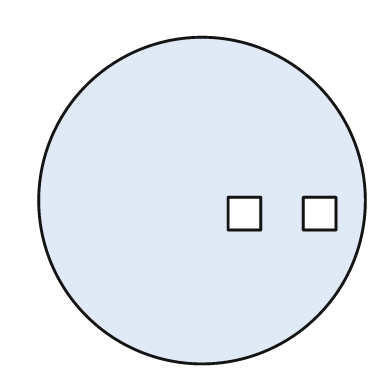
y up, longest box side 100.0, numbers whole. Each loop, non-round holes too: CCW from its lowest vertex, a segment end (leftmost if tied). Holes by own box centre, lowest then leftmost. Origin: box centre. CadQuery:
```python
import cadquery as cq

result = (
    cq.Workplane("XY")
    .moveTo(0.0, 0.0)
    .circle(50.0)
    .moveTo(8.0, -9.0)
    .lineTo(18.0, -9.0)
    .lineTo(18.0, 1.0)
    .lineTo(8.0, 1.0)
    .close()
    .moveTo(31.0, -9.0)
    .lineTo(41.0, -9.0)
    .lineTo(41.0, 1.0)
    .lineTo(31.0, 1.0)
    .close()
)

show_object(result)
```